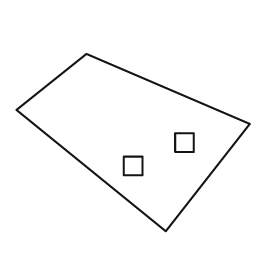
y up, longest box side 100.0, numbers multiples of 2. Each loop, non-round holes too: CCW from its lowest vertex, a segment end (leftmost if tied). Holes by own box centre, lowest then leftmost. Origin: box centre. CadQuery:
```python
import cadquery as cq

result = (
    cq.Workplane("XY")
    .moveTo(14.0, -38.0)
    .lineTo(50.0, 8.0)
    .lineTo(-20.0, 38.0)
    .lineTo(-50.0, 14.0)
    .close()
    .moveTo(-4.0, -14.0)
    .lineTo(4.0, -14.0)
    .lineTo(4.0, -6.0)
    .lineTo(-4.0, -6.0)
    .close()
    .moveTo(18.0, -4.0)
    .lineTo(26.0, -4.0)
    .lineTo(26.0, 4.0)
    .lineTo(18.0, 4.0)
    .close()
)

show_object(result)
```